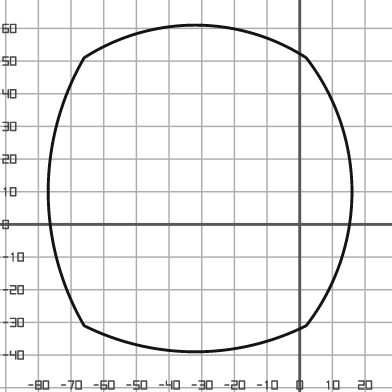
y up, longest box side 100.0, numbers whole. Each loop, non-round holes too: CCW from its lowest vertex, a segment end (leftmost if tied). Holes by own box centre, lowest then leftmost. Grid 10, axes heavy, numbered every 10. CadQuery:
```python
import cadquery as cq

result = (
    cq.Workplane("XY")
    .moveTo(-66.0, -31.0)
    .threePointArc((-32.0, -39.0), (2.0, -31.0))
    .threePointArc((16.0, 10.0), (2.0, 51.0))
    .threePointArc((-32.0, 61.0), (-66.0, 51.0))
    .threePointArc((-77.0, 10.0), (-66.0, -31.0))
    .close()
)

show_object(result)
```